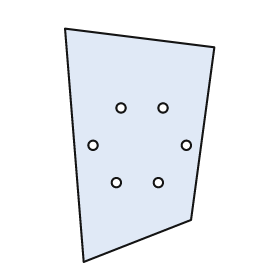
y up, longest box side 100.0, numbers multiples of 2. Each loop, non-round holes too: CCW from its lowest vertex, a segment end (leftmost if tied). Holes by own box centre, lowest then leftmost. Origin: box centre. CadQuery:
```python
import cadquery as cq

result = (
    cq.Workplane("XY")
    .moveTo(-24.0, -50.0)
    .lineTo(22.0, -32.0)
    .lineTo(32.0, 42.0)
    .lineTo(-32.0, 50.0)
    .close()
    .moveTo(-10.0, -16.0)
    .circle(2.0)
    .moveTo(8.0, -16.0)
    .circle(2.0)
    .moveTo(-20.0, 0.0)
    .circle(2.0)
    .moveTo(20.0, 0.0)
    .circle(2.0)
    .moveTo(-8.0, 16.0)
    .circle(2.0)
    .moveTo(10.0, 16.0)
    .circle(2.0)
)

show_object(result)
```